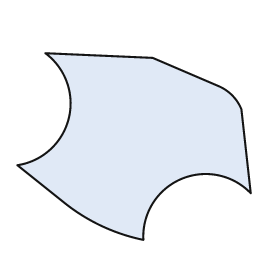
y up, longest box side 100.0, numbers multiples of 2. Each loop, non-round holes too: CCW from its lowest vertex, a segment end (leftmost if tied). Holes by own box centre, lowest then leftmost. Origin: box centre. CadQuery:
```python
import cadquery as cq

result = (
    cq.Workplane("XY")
    .moveTo(4.0, -40.0)
    .threePointArc((20.0, -14.0), (50.0, -20.0))
    .lineTo(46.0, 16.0)
    .threePointArc((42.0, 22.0), (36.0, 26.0))
    .lineTo(8.0, 38.0)
    .lineTo(-38.0, 40.0)
    .threePointArc((-28.0, 12.0), (-50.0, -8.0))
    .lineTo(-30.0, -24.0)
    .threePointArc((-14.0, -34.0), (4.0, -40.0))
    .close()
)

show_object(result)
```